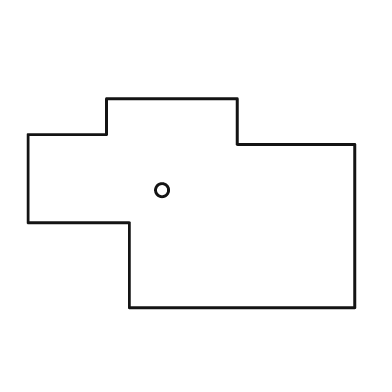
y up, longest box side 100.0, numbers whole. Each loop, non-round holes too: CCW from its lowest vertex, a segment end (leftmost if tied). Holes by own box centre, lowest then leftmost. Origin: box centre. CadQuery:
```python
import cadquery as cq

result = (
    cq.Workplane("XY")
    .moveTo(-19.0, -32.0)
    .lineTo(50.0, -32.0)
    .lineTo(50.0, 18.0)
    .lineTo(14.0, 18.0)
    .lineTo(14.0, 32.0)
    .lineTo(-26.0, 32.0)
    .lineTo(-26.0, 21.0)
    .lineTo(-50.0, 21.0)
    .lineTo(-50.0, -6.0)
    .lineTo(-19.0, -6.0)
    .close()
    .moveTo(-9.0, 4.0)
    .circle(2.0)
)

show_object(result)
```